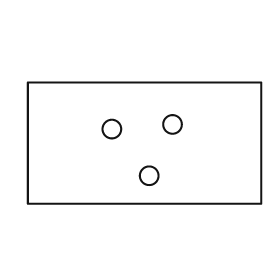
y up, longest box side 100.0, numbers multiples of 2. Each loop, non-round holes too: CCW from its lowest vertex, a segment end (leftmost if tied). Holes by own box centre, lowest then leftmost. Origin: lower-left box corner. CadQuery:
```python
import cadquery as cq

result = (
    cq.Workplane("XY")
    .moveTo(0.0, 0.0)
    .lineTo(100.0, 0.0)
    .lineTo(100.0, 52.0)
    .lineTo(0.0, 52.0)
    .close()
    .moveTo(52.0, 12.0)
    .circle(4.0)
    .moveTo(36.0, 32.0)
    .circle(4.0)
    .moveTo(62.0, 34.0)
    .circle(4.0)
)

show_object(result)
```